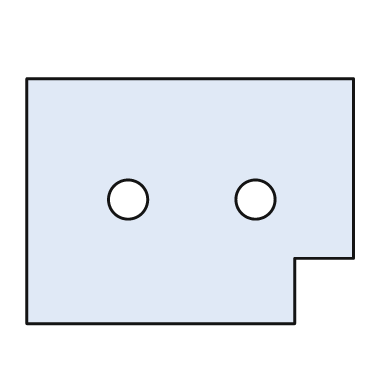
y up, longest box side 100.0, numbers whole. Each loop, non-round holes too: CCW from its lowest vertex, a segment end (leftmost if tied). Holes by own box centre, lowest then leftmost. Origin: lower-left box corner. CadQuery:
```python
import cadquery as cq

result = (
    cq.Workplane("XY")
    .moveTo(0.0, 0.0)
    .lineTo(82.0, 0.0)
    .lineTo(82.0, 20.0)
    .lineTo(100.0, 20.0)
    .lineTo(100.0, 75.0)
    .lineTo(0.0, 75.0)
    .close()
    .moveTo(31.0, 38.0)
    .circle(6.0)
    .moveTo(70.0, 38.0)
    .circle(6.0)
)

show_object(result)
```